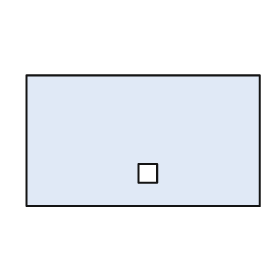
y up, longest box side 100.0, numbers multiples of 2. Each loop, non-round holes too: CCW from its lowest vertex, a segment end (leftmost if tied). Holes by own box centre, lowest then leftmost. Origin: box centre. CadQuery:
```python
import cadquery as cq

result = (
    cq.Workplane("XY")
    .moveTo(-50.0, -28.0)
    .lineTo(50.0, -28.0)
    .lineTo(50.0, 28.0)
    .lineTo(-50.0, 28.0)
    .close()
    .moveTo(-2.0, -18.0)
    .lineTo(6.0, -18.0)
    .lineTo(6.0, -10.0)
    .lineTo(-2.0, -10.0)
    .close()
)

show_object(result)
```